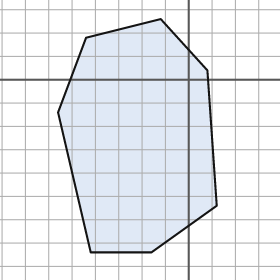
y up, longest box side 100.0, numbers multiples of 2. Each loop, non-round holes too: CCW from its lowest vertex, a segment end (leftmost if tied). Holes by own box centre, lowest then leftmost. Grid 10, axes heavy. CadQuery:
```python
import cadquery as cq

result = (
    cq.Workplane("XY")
    .moveTo(-42.0, -74.0)
    .lineTo(-16.0, -74.0)
    .lineTo(12.0, -54.0)
    .lineTo(8.0, 4.0)
    .lineTo(-12.0, 26.0)
    .lineTo(-44.0, 18.0)
    .lineTo(-56.0, -14.0)
    .close()
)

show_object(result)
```